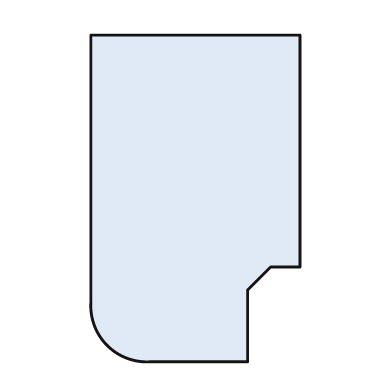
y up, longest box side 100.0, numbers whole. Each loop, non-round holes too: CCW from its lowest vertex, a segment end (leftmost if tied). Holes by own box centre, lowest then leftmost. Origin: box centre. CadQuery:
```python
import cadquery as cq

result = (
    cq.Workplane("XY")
    .moveTo(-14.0, -50.0)
    .lineTo(16.0, -50.0)
    .lineTo(16.0, -28.0)
    .lineTo(23.0, -21.0)
    .lineTo(32.0, -21.0)
    .lineTo(32.0, 50.0)
    .lineTo(-32.0, 50.0)
    .lineTo(-32.0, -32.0)
    .threePointArc((-27.0, -45.0), (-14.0, -50.0))
    .close()
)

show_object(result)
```